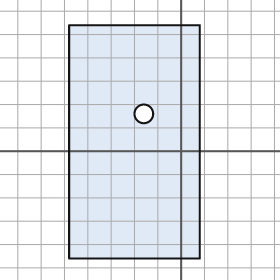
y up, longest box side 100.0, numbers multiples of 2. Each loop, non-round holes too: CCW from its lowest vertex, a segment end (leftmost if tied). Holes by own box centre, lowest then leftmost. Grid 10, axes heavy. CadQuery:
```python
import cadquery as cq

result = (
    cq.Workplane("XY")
    .moveTo(-48.0, -46.0)
    .lineTo(8.0, -46.0)
    .lineTo(8.0, 54.0)
    .lineTo(-48.0, 54.0)
    .close()
    .moveTo(-16.0, 16.0)
    .circle(4.0)
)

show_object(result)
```